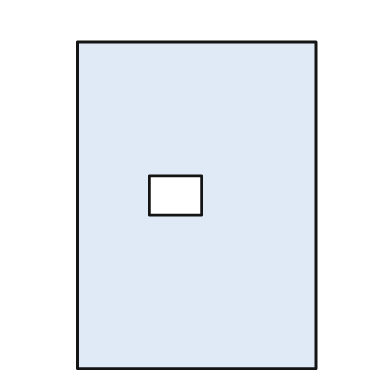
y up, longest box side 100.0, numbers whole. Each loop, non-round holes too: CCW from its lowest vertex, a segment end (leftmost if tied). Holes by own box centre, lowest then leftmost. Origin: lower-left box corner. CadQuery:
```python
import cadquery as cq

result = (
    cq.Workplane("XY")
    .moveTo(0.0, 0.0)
    .lineTo(73.0, 0.0)
    .lineTo(73.0, 100.0)
    .lineTo(0.0, 100.0)
    .close()
    .moveTo(22.0, 47.0)
    .lineTo(38.0, 47.0)
    .lineTo(38.0, 59.0)
    .lineTo(22.0, 59.0)
    .close()
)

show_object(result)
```